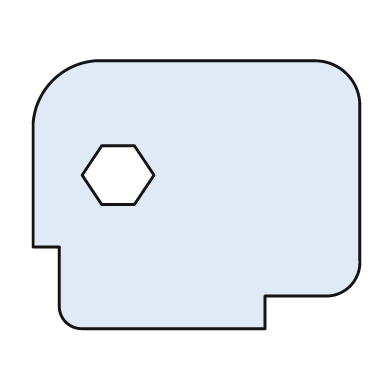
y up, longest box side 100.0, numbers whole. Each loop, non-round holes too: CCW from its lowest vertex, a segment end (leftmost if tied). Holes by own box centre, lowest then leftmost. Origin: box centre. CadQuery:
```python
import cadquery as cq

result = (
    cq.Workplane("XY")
    .moveTo(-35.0, -41.0)
    .lineTo(21.0, -41.0)
    .lineTo(21.0, -31.0)
    .lineTo(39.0, -31.0)
    .threePointArc((47.0, -28.0), (50.0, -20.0))
    .lineTo(50.0, 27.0)
    .threePointArc((46.0, 37.0), (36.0, 41.0))
    .lineTo(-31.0, 41.0)
    .threePointArc((-44.0, 35.0), (-50.0, 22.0))
    .lineTo(-50.0, -16.0)
    .lineTo(-42.0, -16.0)
    .lineTo(-42.0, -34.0)
    .threePointArc((-40.0, -39.0), (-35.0, -41.0))
    .close()
    .moveTo(-29.0, -3.0)
    .lineTo(-19.0, -3.0)
    .lineTo(-13.0, 6.0)
    .lineTo(-19.0, 15.0)
    .lineTo(-29.0, 15.0)
    .lineTo(-35.0, 6.0)
    .close()
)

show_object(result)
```